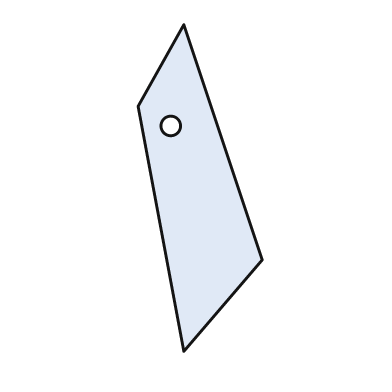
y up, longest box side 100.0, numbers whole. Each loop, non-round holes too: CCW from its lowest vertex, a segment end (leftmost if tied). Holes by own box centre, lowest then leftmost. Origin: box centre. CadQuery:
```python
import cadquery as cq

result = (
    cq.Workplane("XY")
    .moveTo(-5.0, -50.0)
    .lineTo(19.0, -22.0)
    .lineTo(-5.0, 50.0)
    .lineTo(-19.0, 25.0)
    .close()
    .moveTo(-9.0, 19.0)
    .circle(3.0)
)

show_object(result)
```